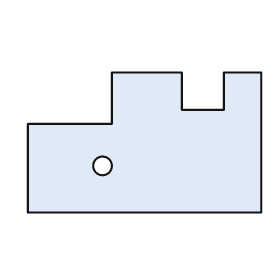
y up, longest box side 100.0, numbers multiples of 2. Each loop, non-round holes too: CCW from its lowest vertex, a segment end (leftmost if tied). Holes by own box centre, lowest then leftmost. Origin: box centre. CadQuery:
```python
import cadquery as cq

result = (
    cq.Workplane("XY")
    .moveTo(-50.0, -30.0)
    .lineTo(50.0, -30.0)
    .lineTo(50.0, 30.0)
    .lineTo(34.0, 30.0)
    .lineTo(34.0, 14.0)
    .lineTo(16.0, 14.0)
    .lineTo(16.0, 30.0)
    .lineTo(-14.0, 30.0)
    .lineTo(-14.0, 8.0)
    .lineTo(-50.0, 8.0)
    .close()
    .moveTo(-18.0, -10.0)
    .circle(4.0)
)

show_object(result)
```